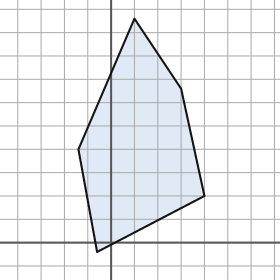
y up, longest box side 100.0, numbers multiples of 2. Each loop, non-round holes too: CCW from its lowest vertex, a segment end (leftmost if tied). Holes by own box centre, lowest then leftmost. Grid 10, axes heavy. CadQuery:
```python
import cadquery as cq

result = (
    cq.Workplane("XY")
    .moveTo(-6.0, -4.0)
    .lineTo(40.0, 20.0)
    .lineTo(30.0, 66.0)
    .lineTo(10.0, 96.0)
    .lineTo(-14.0, 40.0)
    .close()
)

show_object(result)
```